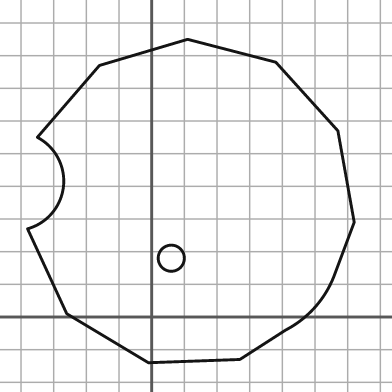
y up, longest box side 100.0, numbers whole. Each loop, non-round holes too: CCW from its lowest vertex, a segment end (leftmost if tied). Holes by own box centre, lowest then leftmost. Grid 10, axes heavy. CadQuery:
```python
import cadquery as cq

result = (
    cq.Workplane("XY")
    .moveTo(-1.0, -14.0)
    .lineTo(27.0, -13.0)
    .lineTo(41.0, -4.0)
    .threePointArc((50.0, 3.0), (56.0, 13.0))
    .lineTo(62.0, 29.0)
    .lineTo(57.0, 57.0)
    .lineTo(38.0, 78.0)
    .lineTo(11.0, 85.0)
    .lineTo(-16.0, 77.0)
    .lineTo(-35.0, 55.0)
    .threePointArc((-27.0, 40.0), (-38.0, 27.0))
    .lineTo(-26.0, 1.0)
    .close()
    .moveTo(6.0, 18.0)
    .circle(4.0)
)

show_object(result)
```